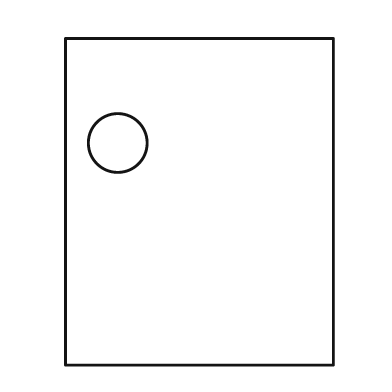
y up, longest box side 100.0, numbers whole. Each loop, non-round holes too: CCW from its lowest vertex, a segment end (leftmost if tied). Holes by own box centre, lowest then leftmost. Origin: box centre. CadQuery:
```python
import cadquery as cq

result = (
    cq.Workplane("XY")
    .moveTo(-41.0, -50.0)
    .lineTo(41.0, -50.0)
    .lineTo(41.0, 50.0)
    .lineTo(-41.0, 50.0)
    .close()
    .moveTo(-25.0, 18.0)
    .circle(9.0)
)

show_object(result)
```